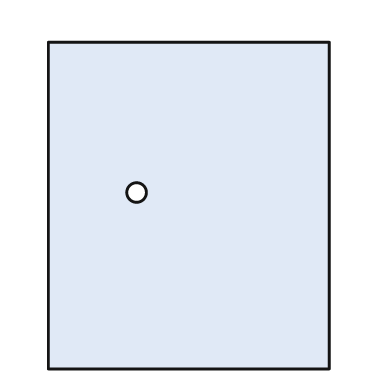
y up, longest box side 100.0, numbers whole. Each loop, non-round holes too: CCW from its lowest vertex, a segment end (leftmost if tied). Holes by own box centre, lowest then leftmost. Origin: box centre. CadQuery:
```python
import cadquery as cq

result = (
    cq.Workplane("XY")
    .moveTo(-43.0, -50.0)
    .lineTo(43.0, -50.0)
    .lineTo(43.0, 50.0)
    .lineTo(-43.0, 50.0)
    .close()
    .moveTo(-16.0, 4.0)
    .circle(3.0)
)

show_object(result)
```